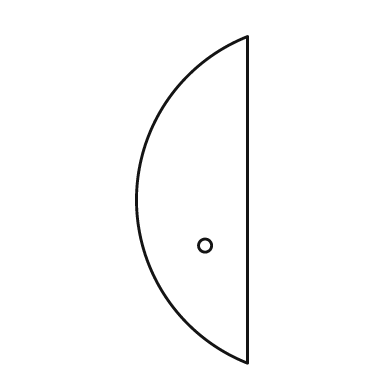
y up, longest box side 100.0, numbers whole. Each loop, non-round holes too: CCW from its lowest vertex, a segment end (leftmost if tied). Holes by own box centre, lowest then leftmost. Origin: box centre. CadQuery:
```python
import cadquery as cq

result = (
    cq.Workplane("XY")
    .moveTo(17.0, -50.0)
    .lineTo(17.0, 50.0)
    .threePointArc((-17.0, 0.0), (17.0, -50.0))
    .close()
    .moveTo(4.0, -14.0)
    .circle(2.0)
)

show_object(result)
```